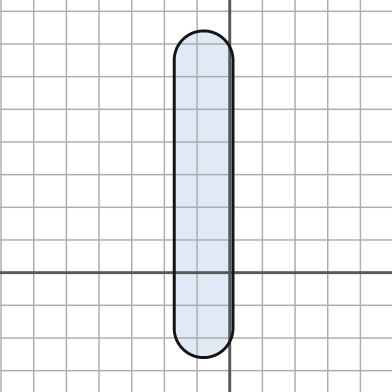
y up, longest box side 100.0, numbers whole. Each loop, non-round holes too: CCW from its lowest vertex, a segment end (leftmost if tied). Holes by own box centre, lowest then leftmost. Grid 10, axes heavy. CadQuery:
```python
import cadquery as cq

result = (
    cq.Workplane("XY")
    .moveTo(-17.0, -17.0)
    .threePointArc((-8.0, -26.0), (1.0, -17.0))
    .lineTo(1.0, 65.0)
    .threePointArc((-8.0, 74.0), (-17.0, 65.0))
    .close()
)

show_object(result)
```